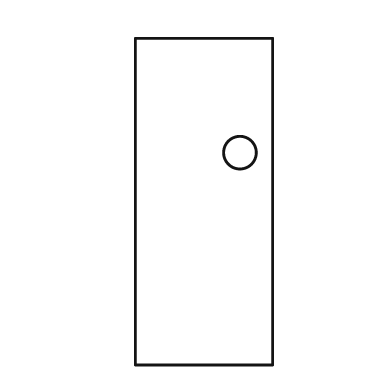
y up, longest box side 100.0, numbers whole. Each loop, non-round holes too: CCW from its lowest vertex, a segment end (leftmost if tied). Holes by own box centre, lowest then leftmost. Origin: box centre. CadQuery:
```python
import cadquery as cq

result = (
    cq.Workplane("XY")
    .moveTo(-21.0, -50.0)
    .lineTo(21.0, -50.0)
    .lineTo(21.0, 50.0)
    .lineTo(-21.0, 50.0)
    .close()
    .moveTo(11.0, 15.0)
    .circle(5.0)
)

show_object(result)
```